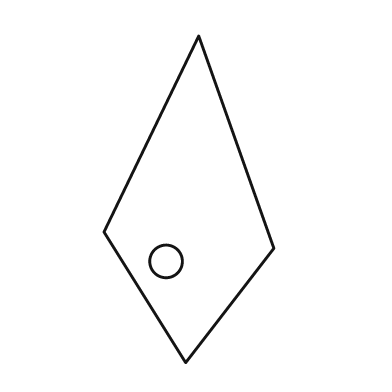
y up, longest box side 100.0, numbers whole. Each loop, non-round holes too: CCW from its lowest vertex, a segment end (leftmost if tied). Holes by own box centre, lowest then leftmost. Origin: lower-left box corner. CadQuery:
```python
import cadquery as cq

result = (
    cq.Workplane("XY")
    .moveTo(25.0, 0.0)
    .lineTo(52.0, 35.0)
    .lineTo(29.0, 100.0)
    .lineTo(0.0, 40.0)
    .close()
    .moveTo(19.0, 31.0)
    .circle(5.0)
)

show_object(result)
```